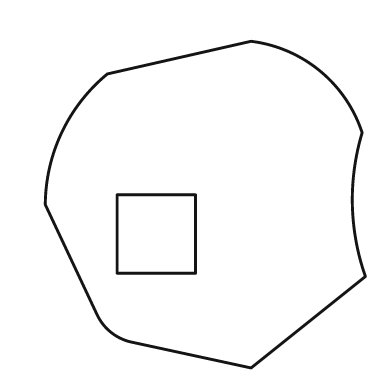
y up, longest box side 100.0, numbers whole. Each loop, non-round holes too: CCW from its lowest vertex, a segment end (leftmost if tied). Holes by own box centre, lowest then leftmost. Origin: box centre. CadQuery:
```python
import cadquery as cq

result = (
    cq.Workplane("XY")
    .moveTo(14.0, -50.0)
    .lineTo(49.0, -22.0)
    .threePointArc((45.0, 0.0), (48.0, 22.0))
    .threePointArc((35.0, 41.0), (14.0, 50.0))
    .lineTo(-30.0, 40.0)
    .threePointArc((-44.0, 22.0), (-49.0, 0.0))
    .lineTo(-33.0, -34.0)
    .threePointArc((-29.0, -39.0), (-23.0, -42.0))
    .close()
    .moveTo(-27.0, -21.0)
    .lineTo(-3.0, -21.0)
    .lineTo(-3.0, 3.0)
    .lineTo(-27.0, 3.0)
    .close()
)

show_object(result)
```